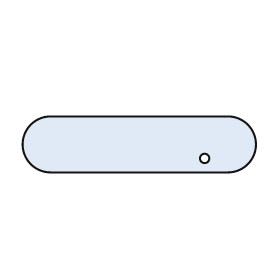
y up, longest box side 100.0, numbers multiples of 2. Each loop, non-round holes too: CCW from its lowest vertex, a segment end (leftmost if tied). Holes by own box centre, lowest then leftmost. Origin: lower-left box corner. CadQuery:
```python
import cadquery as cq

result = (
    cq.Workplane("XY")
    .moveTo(12.0, 0.0)
    .lineTo(88.0, 0.0)
    .threePointArc((100.0, 12.0), (88.0, 24.0))
    .lineTo(12.0, 24.0)
    .threePointArc((0.0, 12.0), (12.0, 0.0))
    .close()
    .moveTo(78.0, 6.0)
    .circle(2.0)
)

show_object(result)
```